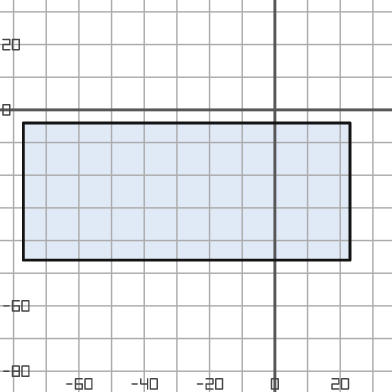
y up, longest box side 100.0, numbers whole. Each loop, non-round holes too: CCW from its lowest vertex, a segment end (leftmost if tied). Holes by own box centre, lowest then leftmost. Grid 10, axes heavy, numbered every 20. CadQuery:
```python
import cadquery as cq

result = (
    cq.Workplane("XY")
    .moveTo(-77.0, -46.0)
    .lineTo(23.0, -46.0)
    .lineTo(23.0, -4.0)
    .lineTo(-77.0, -4.0)
    .close()
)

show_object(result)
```